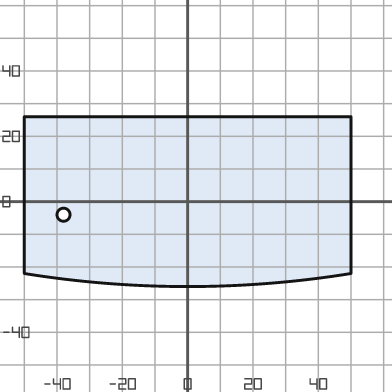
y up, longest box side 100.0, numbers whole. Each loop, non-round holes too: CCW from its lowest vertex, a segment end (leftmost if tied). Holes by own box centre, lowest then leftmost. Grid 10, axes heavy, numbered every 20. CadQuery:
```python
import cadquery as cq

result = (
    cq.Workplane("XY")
    .moveTo(-50.0, -22.0)
    .threePointArc((0.0, -26.0), (50.0, -22.0))
    .lineTo(50.0, 26.0)
    .lineTo(-50.0, 26.0)
    .close()
    .moveTo(-38.0, -4.0)
    .circle(2.0)
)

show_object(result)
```